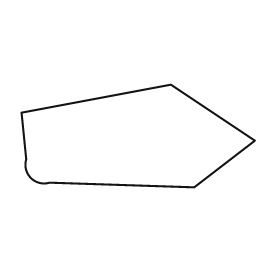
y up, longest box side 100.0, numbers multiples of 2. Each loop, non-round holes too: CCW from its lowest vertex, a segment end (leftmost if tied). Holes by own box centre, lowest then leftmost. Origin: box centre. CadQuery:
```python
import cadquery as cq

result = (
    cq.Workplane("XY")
    .moveTo(24.0, -22.0)
    .lineTo(50.0, -2.0)
    .lineTo(14.0, 22.0)
    .lineTo(-50.0, 10.0)
    .lineTo(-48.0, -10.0)
    .threePointArc((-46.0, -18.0), (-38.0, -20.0))
    .close()
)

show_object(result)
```